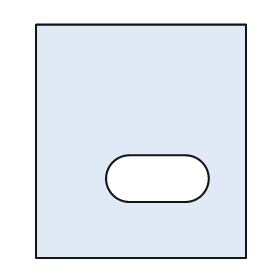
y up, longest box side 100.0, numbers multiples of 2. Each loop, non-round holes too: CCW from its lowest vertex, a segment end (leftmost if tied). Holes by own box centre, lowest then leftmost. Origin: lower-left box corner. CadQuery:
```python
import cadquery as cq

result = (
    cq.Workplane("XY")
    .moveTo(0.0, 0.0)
    .lineTo(90.0, 0.0)
    .lineTo(90.0, 100.0)
    .lineTo(0.0, 100.0)
    .close()
    .moveTo(40.0, 24.0)
    .lineTo(64.0, 24.0)
    .threePointArc((74.0, 34.0), (64.0, 44.0))
    .lineTo(40.0, 44.0)
    .threePointArc((30.0, 34.0), (40.0, 24.0))
    .close()
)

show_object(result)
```